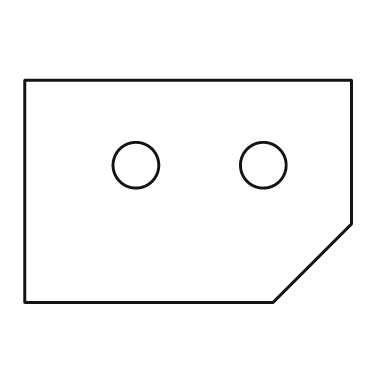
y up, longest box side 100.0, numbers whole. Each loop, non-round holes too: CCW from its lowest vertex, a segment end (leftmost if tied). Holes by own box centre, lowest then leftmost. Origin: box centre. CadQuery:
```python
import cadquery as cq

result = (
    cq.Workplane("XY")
    .moveTo(-50.0, -34.0)
    .lineTo(26.0, -34.0)
    .lineTo(50.0, -10.0)
    .lineTo(50.0, 34.0)
    .lineTo(-50.0, 34.0)
    .close()
    .moveTo(-16.0, 8.0)
    .circle(7.0)
    .moveTo(23.0, 8.0)
    .circle(7.0)
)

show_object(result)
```